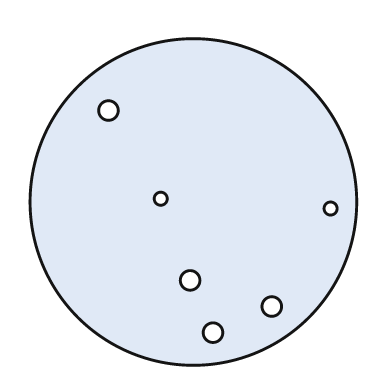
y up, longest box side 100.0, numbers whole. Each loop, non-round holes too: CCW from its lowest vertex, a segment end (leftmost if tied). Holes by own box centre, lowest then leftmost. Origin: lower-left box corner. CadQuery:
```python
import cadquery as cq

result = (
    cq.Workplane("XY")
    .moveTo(50.0, 50.0)
    .circle(50.0)
    .moveTo(56.0, 10.0)
    .circle(3.0)
    .moveTo(74.0, 18.0)
    .circle(3.0)
    .moveTo(49.0, 26.0)
    .circle(3.0)
    .moveTo(92.0, 48.0)
    .circle(2.0)
    .moveTo(40.0, 51.0)
    .circle(2.0)
    .moveTo(24.0, 78.0)
    .circle(3.0)
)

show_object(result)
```